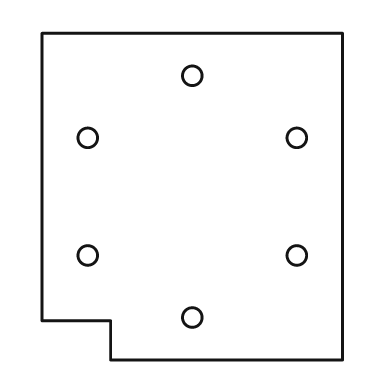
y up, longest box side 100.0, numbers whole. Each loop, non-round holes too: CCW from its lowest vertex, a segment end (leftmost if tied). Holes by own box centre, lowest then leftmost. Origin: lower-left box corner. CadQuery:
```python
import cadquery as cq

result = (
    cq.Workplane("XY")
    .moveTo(21.0, 0.0)
    .lineTo(92.0, 0.0)
    .lineTo(92.0, 100.0)
    .lineTo(0.0, 100.0)
    .lineTo(0.0, 12.0)
    .lineTo(21.0, 12.0)
    .close()
    .moveTo(46.0, 13.0)
    .circle(3.0)
    .moveTo(14.0, 32.0)
    .circle(3.0)
    .moveTo(78.0, 32.0)
    .circle(3.0)
    .moveTo(14.0, 68.0)
    .circle(3.0)
    .moveTo(78.0, 68.0)
    .circle(3.0)
    .moveTo(46.0, 87.0)
    .circle(3.0)
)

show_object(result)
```